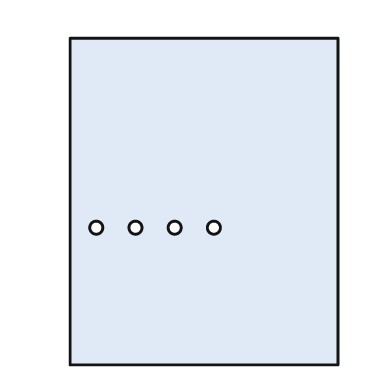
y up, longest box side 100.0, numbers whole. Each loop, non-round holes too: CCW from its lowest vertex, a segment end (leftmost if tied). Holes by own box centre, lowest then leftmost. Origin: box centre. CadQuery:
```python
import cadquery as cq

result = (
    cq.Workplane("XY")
    .moveTo(-41.0, -50.0)
    .lineTo(41.0, -50.0)
    .lineTo(41.0, 50.0)
    .lineTo(-41.0, 50.0)
    .close()
    .moveTo(-33.0, -8.0)
    .circle(2.0)
    .moveTo(-21.0, -8.0)
    .circle(2.0)
    .moveTo(-9.0, -8.0)
    .circle(2.0)
    .moveTo(3.0, -8.0)
    .circle(2.0)
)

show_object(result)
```